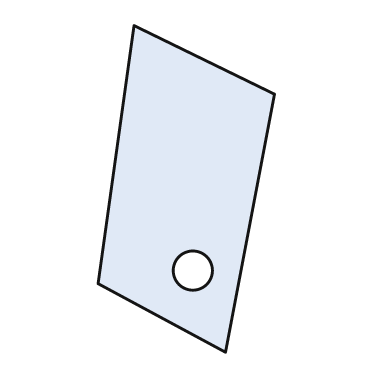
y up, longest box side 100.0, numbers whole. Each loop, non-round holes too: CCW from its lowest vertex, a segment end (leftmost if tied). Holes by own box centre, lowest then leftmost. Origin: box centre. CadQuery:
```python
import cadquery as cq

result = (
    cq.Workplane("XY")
    .moveTo(12.0, -50.0)
    .lineTo(27.0, 29.0)
    .lineTo(-16.0, 50.0)
    .lineTo(-27.0, -29.0)
    .close()
    .moveTo(2.0, -25.0)
    .circle(6.0)
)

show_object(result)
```